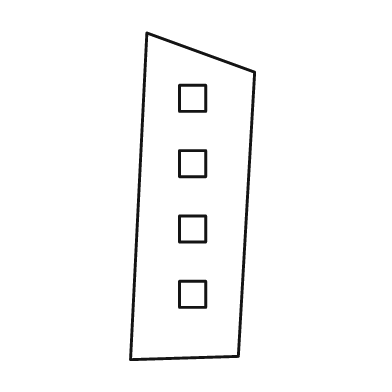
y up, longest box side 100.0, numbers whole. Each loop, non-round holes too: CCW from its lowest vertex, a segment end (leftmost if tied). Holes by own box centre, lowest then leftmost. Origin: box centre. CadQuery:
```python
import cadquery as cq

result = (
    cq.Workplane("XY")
    .moveTo(-19.0, -50.0)
    .lineTo(14.0, -49.0)
    .lineTo(19.0, 38.0)
    .lineTo(-14.0, 50.0)
    .close()
    .moveTo(-4.0, -34.0)
    .lineTo(4.0, -34.0)
    .lineTo(4.0, -26.0)
    .lineTo(-4.0, -26.0)
    .close()
    .moveTo(-4.0, -14.0)
    .lineTo(4.0, -14.0)
    .lineTo(4.0, -6.0)
    .lineTo(-4.0, -6.0)
    .close()
    .moveTo(-4.0, 6.0)
    .lineTo(4.0, 6.0)
    .lineTo(4.0, 14.0)
    .lineTo(-4.0, 14.0)
    .close()
    .moveTo(-4.0, 26.0)
    .lineTo(4.0, 26.0)
    .lineTo(4.0, 34.0)
    .lineTo(-4.0, 34.0)
    .close()
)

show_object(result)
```